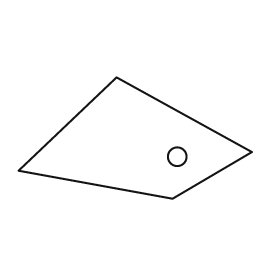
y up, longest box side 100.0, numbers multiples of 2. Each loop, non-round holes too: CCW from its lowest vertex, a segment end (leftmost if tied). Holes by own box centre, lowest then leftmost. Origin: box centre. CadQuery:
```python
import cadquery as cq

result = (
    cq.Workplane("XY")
    .moveTo(16.0, -26.0)
    .lineTo(50.0, -6.0)
    .lineTo(-8.0, 26.0)
    .lineTo(-50.0, -14.0)
    .close()
    .moveTo(18.0, -8.0)
    .circle(4.0)
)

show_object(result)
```